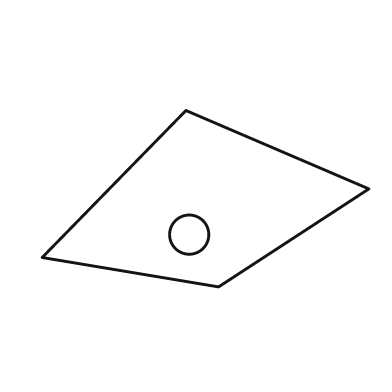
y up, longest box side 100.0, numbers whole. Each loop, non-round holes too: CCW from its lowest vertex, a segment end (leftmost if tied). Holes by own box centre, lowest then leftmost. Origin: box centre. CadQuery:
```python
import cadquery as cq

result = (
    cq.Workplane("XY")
    .moveTo(4.0, -27.0)
    .lineTo(50.0, 3.0)
    .lineTo(-6.0, 27.0)
    .lineTo(-50.0, -18.0)
    .close()
    .moveTo(-5.0, -11.0)
    .circle(6.0)
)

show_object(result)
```